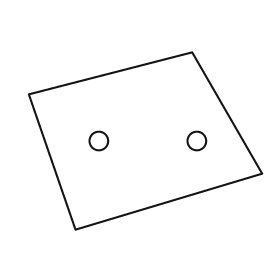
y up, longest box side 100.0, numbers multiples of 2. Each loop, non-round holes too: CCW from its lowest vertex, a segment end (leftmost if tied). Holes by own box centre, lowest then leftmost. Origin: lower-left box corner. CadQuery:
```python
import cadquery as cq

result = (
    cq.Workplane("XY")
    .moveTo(20.0, 0.0)
    .lineTo(100.0, 24.0)
    .lineTo(70.0, 76.0)
    .lineTo(0.0, 58.0)
    .close()
    .moveTo(30.0, 38.0)
    .circle(4.0)
    .moveTo(72.0, 38.0)
    .circle(4.0)
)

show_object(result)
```